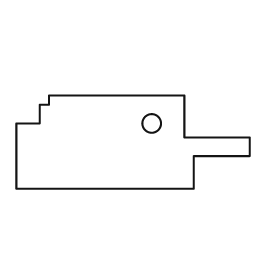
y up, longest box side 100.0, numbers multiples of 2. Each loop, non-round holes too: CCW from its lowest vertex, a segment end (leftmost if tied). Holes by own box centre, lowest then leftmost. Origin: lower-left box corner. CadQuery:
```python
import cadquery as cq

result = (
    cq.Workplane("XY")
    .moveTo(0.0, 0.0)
    .lineTo(76.0, 0.0)
    .lineTo(76.0, 14.0)
    .lineTo(100.0, 14.0)
    .lineTo(100.0, 22.0)
    .lineTo(72.0, 22.0)
    .lineTo(72.0, 40.0)
    .lineTo(14.0, 40.0)
    .lineTo(14.0, 36.0)
    .lineTo(10.0, 36.0)
    .lineTo(10.0, 28.0)
    .lineTo(0.0, 28.0)
    .close()
    .moveTo(58.0, 28.0)
    .circle(4.0)
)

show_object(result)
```